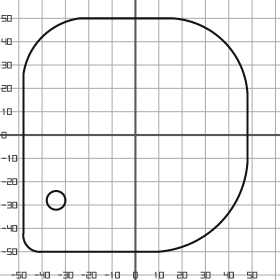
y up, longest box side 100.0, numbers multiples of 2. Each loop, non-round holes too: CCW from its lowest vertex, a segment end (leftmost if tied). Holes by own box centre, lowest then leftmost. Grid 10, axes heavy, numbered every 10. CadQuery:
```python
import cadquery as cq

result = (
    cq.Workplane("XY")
    .moveTo(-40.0, -50.0)
    .lineTo(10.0, -50.0)
    .threePointArc((36.0, -38.0), (48.0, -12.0))
    .lineTo(48.0, 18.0)
    .threePointArc((38.0, 40.0), (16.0, 50.0))
    .lineTo(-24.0, 50.0)
    .threePointArc((-40.0, 42.0), (-48.0, 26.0))
    .lineTo(-48.0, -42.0)
    .threePointArc((-46.0, -48.0), (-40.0, -50.0))
    .close()
    .moveTo(-34.0, -28.0)
    .circle(4.0)
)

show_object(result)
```